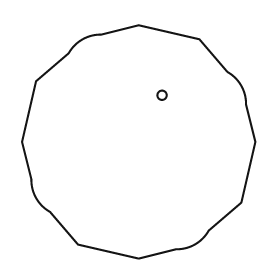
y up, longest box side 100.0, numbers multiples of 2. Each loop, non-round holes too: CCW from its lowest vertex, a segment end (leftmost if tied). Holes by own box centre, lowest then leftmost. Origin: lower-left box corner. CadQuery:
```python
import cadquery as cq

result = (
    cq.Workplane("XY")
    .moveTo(50.0, 0.0)
    .lineTo(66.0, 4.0)
    .threePointArc((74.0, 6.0), (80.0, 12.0))
    .lineTo(94.0, 24.0)
    .lineTo(100.0, 50.0)
    .lineTo(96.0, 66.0)
    .threePointArc((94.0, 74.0), (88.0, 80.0))
    .lineTo(76.0, 94.0)
    .lineTo(50.0, 100.0)
    .lineTo(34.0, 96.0)
    .threePointArc((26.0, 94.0), (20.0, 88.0))
    .lineTo(6.0, 76.0)
    .lineTo(0.0, 50.0)
    .lineTo(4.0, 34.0)
    .threePointArc((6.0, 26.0), (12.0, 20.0))
    .lineTo(24.0, 6.0)
    .close()
    .moveTo(60.0, 70.0)
    .circle(2.0)
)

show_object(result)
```